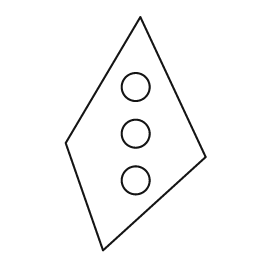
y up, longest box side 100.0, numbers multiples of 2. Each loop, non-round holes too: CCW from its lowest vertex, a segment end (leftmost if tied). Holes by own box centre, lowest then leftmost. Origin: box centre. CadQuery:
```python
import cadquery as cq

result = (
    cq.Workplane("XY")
    .moveTo(-14.0, -50.0)
    .lineTo(30.0, -10.0)
    .lineTo(2.0, 50.0)
    .lineTo(-30.0, -4.0)
    .close()
    .moveTo(0.0, -20.0)
    .circle(6.0)
    .moveTo(0.0, 0.0)
    .circle(6.0)
    .moveTo(0.0, 20.0)
    .circle(6.0)
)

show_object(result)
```